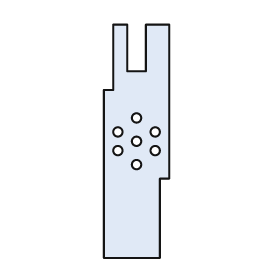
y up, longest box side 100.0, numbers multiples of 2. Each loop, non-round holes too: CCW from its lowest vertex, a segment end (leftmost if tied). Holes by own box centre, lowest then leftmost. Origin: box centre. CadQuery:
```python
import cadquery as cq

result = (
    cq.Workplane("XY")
    .moveTo(-14.0, -50.0)
    .lineTo(10.0, -50.0)
    .lineTo(10.0, -16.0)
    .lineTo(14.0, -16.0)
    .lineTo(14.0, 50.0)
    .lineTo(4.0, 50.0)
    .lineTo(4.0, 30.0)
    .lineTo(-4.0, 30.0)
    .lineTo(-4.0, 50.0)
    .lineTo(-10.0, 50.0)
    .lineTo(-10.0, 22.0)
    .lineTo(-14.0, 22.0)
    .close()
    .moveTo(0.0, -10.0)
    .circle(2.0)
    .moveTo(-8.0, -4.0)
    .circle(2.0)
    .moveTo(8.0, -4.0)
    .circle(2.0)
    .moveTo(0.0, 0.0)
    .circle(2.0)
    .moveTo(-8.0, 4.0)
    .circle(2.0)
    .moveTo(8.0, 4.0)
    .circle(2.0)
    .moveTo(0.0, 10.0)
    .circle(2.0)
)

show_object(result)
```